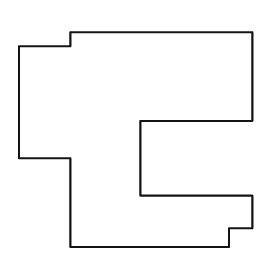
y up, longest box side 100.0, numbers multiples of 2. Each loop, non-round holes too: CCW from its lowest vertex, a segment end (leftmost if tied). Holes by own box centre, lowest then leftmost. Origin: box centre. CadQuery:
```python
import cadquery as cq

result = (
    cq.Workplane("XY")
    .moveTo(-28.0, -46.0)
    .lineTo(40.0, -46.0)
    .lineTo(40.0, -38.0)
    .lineTo(50.0, -38.0)
    .lineTo(50.0, -24.0)
    .lineTo(2.0, -24.0)
    .lineTo(2.0, 8.0)
    .lineTo(50.0, 8.0)
    .lineTo(50.0, 46.0)
    .lineTo(-28.0, 46.0)
    .lineTo(-28.0, 40.0)
    .lineTo(-50.0, 40.0)
    .lineTo(-50.0, -8.0)
    .lineTo(-28.0, -8.0)
    .close()
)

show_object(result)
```